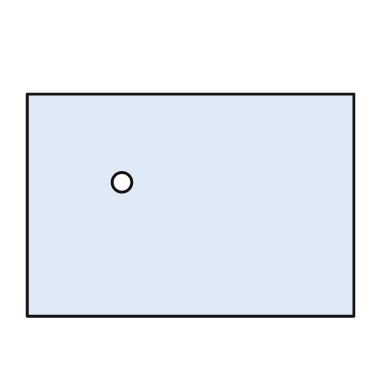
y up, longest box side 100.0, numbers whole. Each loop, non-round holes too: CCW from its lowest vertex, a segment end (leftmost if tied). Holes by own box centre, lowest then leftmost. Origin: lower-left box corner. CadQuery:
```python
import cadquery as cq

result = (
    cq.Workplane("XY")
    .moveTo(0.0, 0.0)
    .lineTo(100.0, 0.0)
    .lineTo(100.0, 68.0)
    .lineTo(0.0, 68.0)
    .close()
    .moveTo(29.0, 41.0)
    .circle(3.0)
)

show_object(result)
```